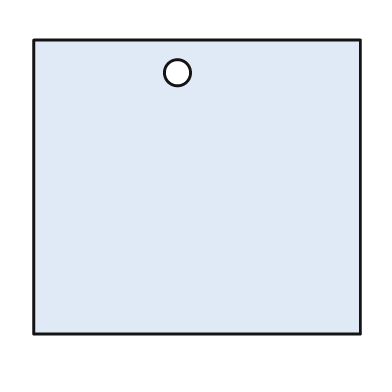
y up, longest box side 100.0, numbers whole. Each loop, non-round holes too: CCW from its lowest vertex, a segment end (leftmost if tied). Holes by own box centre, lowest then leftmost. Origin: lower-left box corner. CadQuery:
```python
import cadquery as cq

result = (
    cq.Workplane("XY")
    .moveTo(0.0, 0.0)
    .lineTo(100.0, 0.0)
    .lineTo(100.0, 90.0)
    .lineTo(0.0, 90.0)
    .close()
    .moveTo(44.0, 80.0)
    .circle(4.0)
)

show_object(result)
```